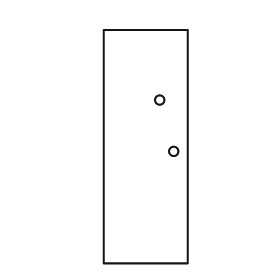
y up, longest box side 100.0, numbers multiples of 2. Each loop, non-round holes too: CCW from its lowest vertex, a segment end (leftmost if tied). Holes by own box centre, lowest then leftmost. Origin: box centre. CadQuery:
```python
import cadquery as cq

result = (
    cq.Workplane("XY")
    .moveTo(-18.0, -50.0)
    .lineTo(18.0, -50.0)
    .lineTo(18.0, 50.0)
    .lineTo(-18.0, 50.0)
    .close()
    .moveTo(12.0, -2.0)
    .circle(2.0)
    .moveTo(6.0, 20.0)
    .circle(2.0)
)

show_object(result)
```